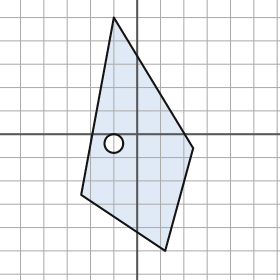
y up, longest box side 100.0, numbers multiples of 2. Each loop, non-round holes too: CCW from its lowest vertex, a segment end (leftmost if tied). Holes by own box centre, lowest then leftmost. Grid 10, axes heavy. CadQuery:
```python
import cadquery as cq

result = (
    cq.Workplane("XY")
    .moveTo(12.0, -50.0)
    .lineTo(24.0, -6.0)
    .lineTo(-10.0, 50.0)
    .lineTo(-24.0, -26.0)
    .close()
    .moveTo(-10.0, -4.0)
    .circle(4.0)
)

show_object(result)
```